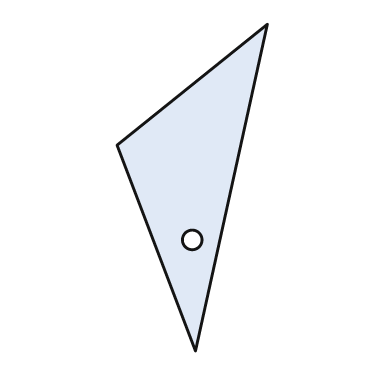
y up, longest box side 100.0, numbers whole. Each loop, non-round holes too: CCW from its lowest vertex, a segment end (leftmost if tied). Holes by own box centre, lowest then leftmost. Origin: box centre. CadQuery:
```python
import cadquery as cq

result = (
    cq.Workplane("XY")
    .moveTo(1.0, -50.0)
    .lineTo(23.0, 50.0)
    .lineTo(-23.0, 13.0)
    .close()
    .moveTo(0.0, -16.0)
    .circle(3.0)
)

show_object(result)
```